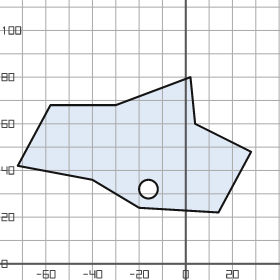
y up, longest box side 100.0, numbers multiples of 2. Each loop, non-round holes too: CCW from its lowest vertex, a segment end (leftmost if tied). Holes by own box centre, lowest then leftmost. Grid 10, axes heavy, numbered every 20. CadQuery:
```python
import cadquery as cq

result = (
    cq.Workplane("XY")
    .moveTo(14.0, 22.0)
    .lineTo(28.0, 48.0)
    .lineTo(4.0, 60.0)
    .lineTo(2.0, 80.0)
    .lineTo(-30.0, 68.0)
    .lineTo(-58.0, 68.0)
    .lineTo(-72.0, 42.0)
    .lineTo(-40.0, 36.0)
    .lineTo(-20.0, 24.0)
    .close()
    .moveTo(-16.0, 32.0)
    .circle(4.0)
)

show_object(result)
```